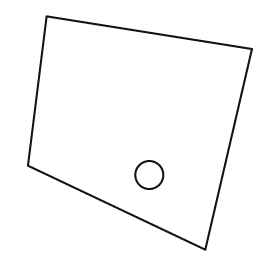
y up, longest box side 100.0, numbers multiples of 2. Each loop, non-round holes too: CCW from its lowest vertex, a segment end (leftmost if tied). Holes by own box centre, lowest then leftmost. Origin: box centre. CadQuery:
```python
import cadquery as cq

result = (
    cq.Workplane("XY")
    .moveTo(28.0, -50.0)
    .lineTo(48.0, 36.0)
    .lineTo(-40.0, 50.0)
    .lineTo(-48.0, -14.0)
    .close()
    .moveTo(4.0, -18.0)
    .circle(6.0)
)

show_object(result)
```